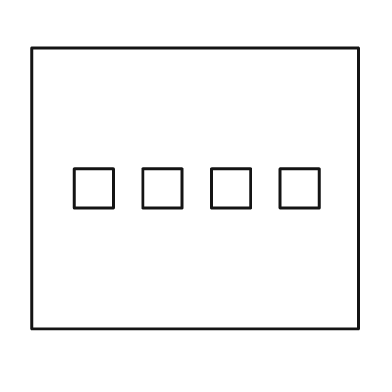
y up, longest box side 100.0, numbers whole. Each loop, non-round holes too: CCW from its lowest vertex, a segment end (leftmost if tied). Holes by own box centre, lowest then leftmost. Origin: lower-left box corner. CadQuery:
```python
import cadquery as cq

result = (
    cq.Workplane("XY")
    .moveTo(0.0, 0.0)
    .lineTo(100.0, 0.0)
    .lineTo(100.0, 86.0)
    .lineTo(0.0, 86.0)
    .close()
    .moveTo(13.0, 37.0)
    .lineTo(25.0, 37.0)
    .lineTo(25.0, 49.0)
    .lineTo(13.0, 49.0)
    .close()
    .moveTo(34.0, 37.0)
    .lineTo(46.0, 37.0)
    .lineTo(46.0, 49.0)
    .lineTo(34.0, 49.0)
    .close()
    .moveTo(55.0, 37.0)
    .lineTo(67.0, 37.0)
    .lineTo(67.0, 49.0)
    .lineTo(55.0, 49.0)
    .close()
    .moveTo(76.0, 37.0)
    .lineTo(88.0, 37.0)
    .lineTo(88.0, 49.0)
    .lineTo(76.0, 49.0)
    .close()
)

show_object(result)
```